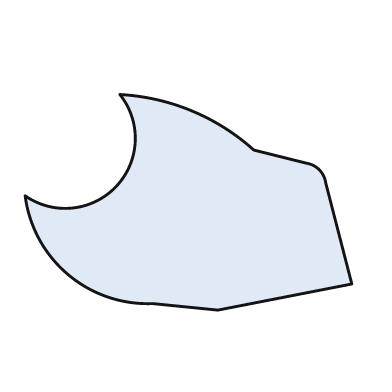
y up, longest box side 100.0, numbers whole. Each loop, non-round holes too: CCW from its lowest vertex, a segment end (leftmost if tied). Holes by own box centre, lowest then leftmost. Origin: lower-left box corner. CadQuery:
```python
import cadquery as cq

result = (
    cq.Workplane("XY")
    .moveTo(59.0, 0.0)
    .lineTo(100.0, 8.0)
    .lineTo(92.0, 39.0)
    .threePointArc((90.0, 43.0), (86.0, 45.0))
    .lineTo(70.0, 49.0)
    .threePointArc((51.0, 61.0), (29.0, 66.0))
    .threePointArc((28.0, 38.0), (0.0, 35.0))
    .threePointArc((13.0, 11.0), (39.0, 2.0))
    .close()
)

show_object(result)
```